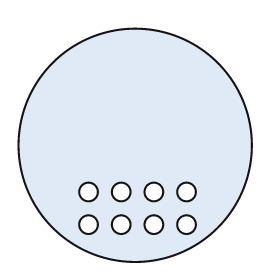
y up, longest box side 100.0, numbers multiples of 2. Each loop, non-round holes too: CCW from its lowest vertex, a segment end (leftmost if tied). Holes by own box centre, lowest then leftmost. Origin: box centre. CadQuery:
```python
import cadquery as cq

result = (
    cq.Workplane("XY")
    .moveTo(0.0, 0.0)
    .circle(50.0)
    .moveTo(-20.0, -34.0)
    .circle(4.0)
    .moveTo(-6.0, -34.0)
    .circle(4.0)
    .moveTo(8.0, -34.0)
    .circle(4.0)
    .moveTo(22.0, -34.0)
    .circle(4.0)
    .moveTo(-20.0, -20.0)
    .circle(4.0)
    .moveTo(-6.0, -20.0)
    .circle(4.0)
    .moveTo(8.0, -20.0)
    .circle(4.0)
    .moveTo(22.0, -20.0)
    .circle(4.0)
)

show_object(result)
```